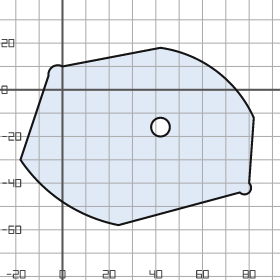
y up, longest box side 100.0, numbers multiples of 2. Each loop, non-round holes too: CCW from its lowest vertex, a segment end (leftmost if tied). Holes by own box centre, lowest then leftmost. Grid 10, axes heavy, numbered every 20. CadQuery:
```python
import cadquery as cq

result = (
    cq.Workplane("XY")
    .moveTo(24.0, -58.0)
    .lineTo(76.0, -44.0)
    .threePointArc((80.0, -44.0), (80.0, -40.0))
    .lineTo(82.0, -12.0)
    .threePointArc((66.0, 8.0), (42.0, 18.0))
    .lineTo(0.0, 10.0)
    .threePointArc((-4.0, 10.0), (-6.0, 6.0))
    .lineTo(-18.0, -30.0)
    .threePointArc((0.0, -48.0), (24.0, -58.0))
    .close()
    .moveTo(42.0, -16.0)
    .circle(4.0)
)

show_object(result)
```